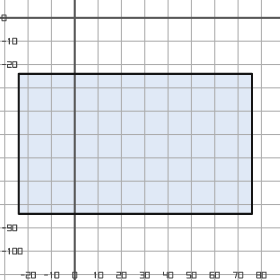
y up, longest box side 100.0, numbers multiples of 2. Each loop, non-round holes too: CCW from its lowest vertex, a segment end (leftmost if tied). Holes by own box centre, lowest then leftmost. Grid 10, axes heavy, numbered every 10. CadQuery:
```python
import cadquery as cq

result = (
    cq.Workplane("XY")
    .moveTo(-24.0, -84.0)
    .lineTo(76.0, -84.0)
    .lineTo(76.0, -24.0)
    .lineTo(-24.0, -24.0)
    .close()
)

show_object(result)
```